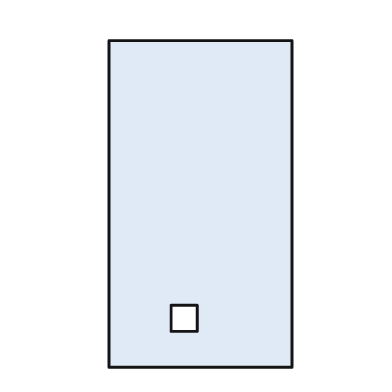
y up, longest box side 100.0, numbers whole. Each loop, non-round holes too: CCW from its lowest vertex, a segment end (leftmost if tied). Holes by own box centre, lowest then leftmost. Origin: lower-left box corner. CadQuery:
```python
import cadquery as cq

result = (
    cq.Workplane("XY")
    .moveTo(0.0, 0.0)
    .lineTo(56.0, 0.0)
    .lineTo(56.0, 100.0)
    .lineTo(0.0, 100.0)
    .close()
    .moveTo(19.0, 11.0)
    .lineTo(27.0, 11.0)
    .lineTo(27.0, 19.0)
    .lineTo(19.0, 19.0)
    .close()
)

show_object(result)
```